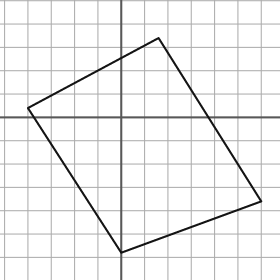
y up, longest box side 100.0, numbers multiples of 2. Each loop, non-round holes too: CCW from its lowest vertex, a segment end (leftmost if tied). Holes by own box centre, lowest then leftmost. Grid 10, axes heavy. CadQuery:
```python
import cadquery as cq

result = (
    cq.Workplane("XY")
    .moveTo(0.0, -58.0)
    .lineTo(60.0, -36.0)
    .lineTo(16.0, 34.0)
    .lineTo(-40.0, 4.0)
    .close()
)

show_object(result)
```